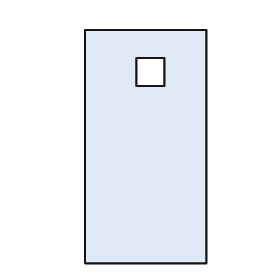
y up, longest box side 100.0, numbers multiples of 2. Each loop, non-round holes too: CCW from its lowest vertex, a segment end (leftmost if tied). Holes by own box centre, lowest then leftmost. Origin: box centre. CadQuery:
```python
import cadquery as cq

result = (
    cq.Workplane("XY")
    .moveTo(-26.0, -50.0)
    .lineTo(26.0, -50.0)
    .lineTo(26.0, 50.0)
    .lineTo(-26.0, 50.0)
    .close()
    .moveTo(-4.0, 26.0)
    .lineTo(8.0, 26.0)
    .lineTo(8.0, 38.0)
    .lineTo(-4.0, 38.0)
    .close()
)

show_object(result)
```